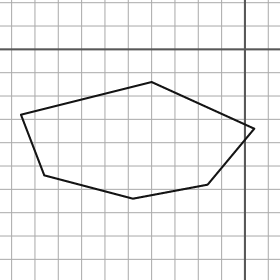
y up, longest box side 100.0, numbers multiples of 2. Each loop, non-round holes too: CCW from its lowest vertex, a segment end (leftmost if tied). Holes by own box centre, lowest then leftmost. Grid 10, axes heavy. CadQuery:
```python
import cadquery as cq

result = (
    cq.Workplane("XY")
    .moveTo(-48.0, -64.0)
    .lineTo(-16.0, -58.0)
    .lineTo(4.0, -34.0)
    .lineTo(-40.0, -14.0)
    .lineTo(-96.0, -28.0)
    .lineTo(-86.0, -54.0)
    .close()
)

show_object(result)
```